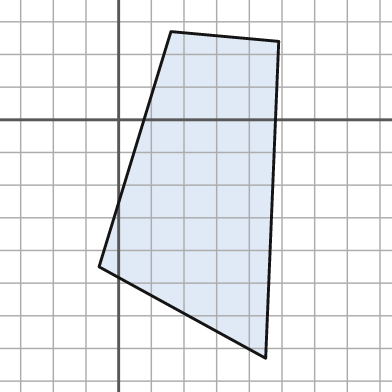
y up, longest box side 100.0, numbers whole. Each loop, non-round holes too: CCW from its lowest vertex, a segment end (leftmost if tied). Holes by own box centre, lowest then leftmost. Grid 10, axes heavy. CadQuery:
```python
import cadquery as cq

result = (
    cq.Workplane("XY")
    .moveTo(45.0, -73.0)
    .lineTo(49.0, 24.0)
    .lineTo(16.0, 27.0)
    .lineTo(-6.0, -45.0)
    .close()
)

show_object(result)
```